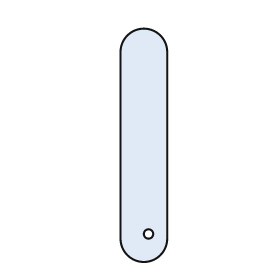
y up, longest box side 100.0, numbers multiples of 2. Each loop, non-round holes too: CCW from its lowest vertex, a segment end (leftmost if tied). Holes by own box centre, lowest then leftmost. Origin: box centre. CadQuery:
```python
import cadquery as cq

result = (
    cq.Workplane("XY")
    .moveTo(-10.0, -40.0)
    .threePointArc((0.0, -50.0), (10.0, -40.0))
    .lineTo(10.0, 40.0)
    .threePointArc((0.0, 50.0), (-10.0, 40.0))
    .close()
    .moveTo(2.0, -38.0)
    .circle(2.0)
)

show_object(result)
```